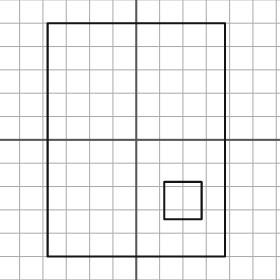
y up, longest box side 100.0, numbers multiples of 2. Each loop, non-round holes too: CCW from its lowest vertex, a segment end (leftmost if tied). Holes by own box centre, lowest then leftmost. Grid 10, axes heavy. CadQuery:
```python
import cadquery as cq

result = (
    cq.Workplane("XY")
    .moveTo(-38.0, -50.0)
    .lineTo(38.0, -50.0)
    .lineTo(38.0, 50.0)
    .lineTo(-38.0, 50.0)
    .close()
    .moveTo(12.0, -34.0)
    .lineTo(28.0, -34.0)
    .lineTo(28.0, -18.0)
    .lineTo(12.0, -18.0)
    .close()
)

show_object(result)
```